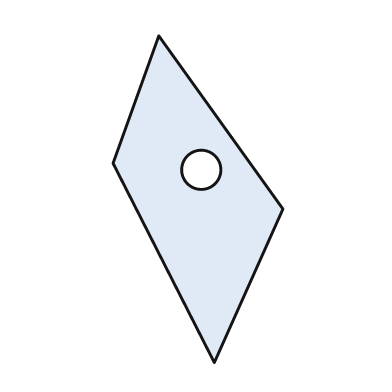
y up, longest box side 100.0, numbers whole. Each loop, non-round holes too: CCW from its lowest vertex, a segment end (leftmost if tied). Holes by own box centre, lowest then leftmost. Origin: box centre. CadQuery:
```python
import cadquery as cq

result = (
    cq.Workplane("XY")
    .moveTo(5.0, -50.0)
    .lineTo(26.0, -3.0)
    .lineTo(-12.0, 50.0)
    .lineTo(-26.0, 11.0)
    .close()
    .moveTo(1.0, 9.0)
    .circle(6.0)
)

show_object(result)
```